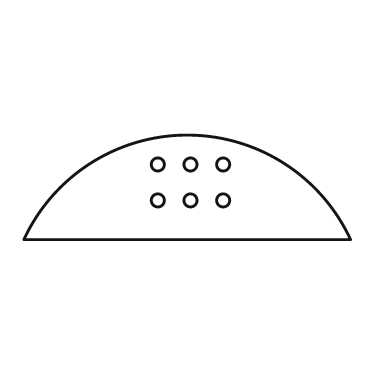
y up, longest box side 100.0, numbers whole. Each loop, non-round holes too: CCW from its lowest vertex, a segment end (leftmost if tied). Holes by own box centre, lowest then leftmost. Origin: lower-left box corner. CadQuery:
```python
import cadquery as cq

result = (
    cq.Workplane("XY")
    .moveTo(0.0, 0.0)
    .lineTo(100.0, 0.0)
    .threePointArc((50.0, 32.0), (0.0, 0.0))
    .close()
    .moveTo(41.0, 12.0)
    .circle(2.0)
    .moveTo(51.0, 12.0)
    .circle(2.0)
    .moveTo(61.0, 12.0)
    .circle(2.0)
    .moveTo(41.0, 23.0)
    .circle(2.0)
    .moveTo(51.0, 23.0)
    .circle(2.0)
    .moveTo(61.0, 23.0)
    .circle(2.0)
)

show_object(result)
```